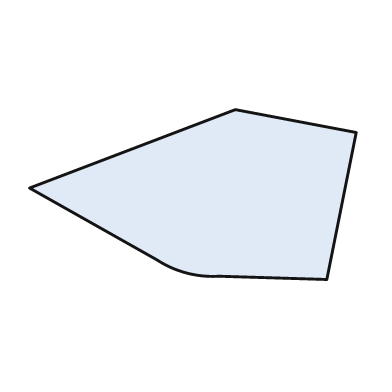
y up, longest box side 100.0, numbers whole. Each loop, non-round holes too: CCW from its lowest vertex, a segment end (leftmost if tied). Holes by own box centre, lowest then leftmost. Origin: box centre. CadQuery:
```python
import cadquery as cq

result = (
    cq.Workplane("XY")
    .moveTo(41.0, -26.0)
    .lineTo(50.0, 19.0)
    .lineTo(13.0, 26.0)
    .lineTo(-50.0, 2.0)
    .lineTo(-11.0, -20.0)
    .threePointArc((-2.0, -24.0), (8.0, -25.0))
    .close()
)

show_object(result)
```